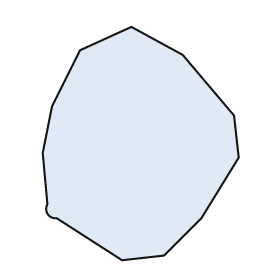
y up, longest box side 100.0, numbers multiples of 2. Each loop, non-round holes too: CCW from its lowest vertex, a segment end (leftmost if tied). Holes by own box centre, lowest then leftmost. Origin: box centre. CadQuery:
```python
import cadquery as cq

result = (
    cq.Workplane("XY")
    .moveTo(-8.0, -50.0)
    .lineTo(10.0, -48.0)
    .lineTo(26.0, -32.0)
    .lineTo(42.0, -6.0)
    .lineTo(40.0, 12.0)
    .lineTo(18.0, 38.0)
    .lineTo(-4.0, 50.0)
    .lineTo(-26.0, 40.0)
    .lineTo(-38.0, 16.0)
    .lineTo(-42.0, -4.0)
    .lineTo(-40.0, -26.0)
    .threePointArc((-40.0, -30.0), (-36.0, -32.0))
    .close()
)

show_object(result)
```